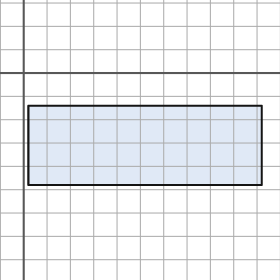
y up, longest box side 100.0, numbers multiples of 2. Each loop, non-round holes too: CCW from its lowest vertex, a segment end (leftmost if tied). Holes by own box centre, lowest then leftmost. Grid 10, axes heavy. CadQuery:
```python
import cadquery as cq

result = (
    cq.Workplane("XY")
    .moveTo(2.0, -48.0)
    .lineTo(102.0, -48.0)
    .lineTo(102.0, -14.0)
    .lineTo(2.0, -14.0)
    .close()
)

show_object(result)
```